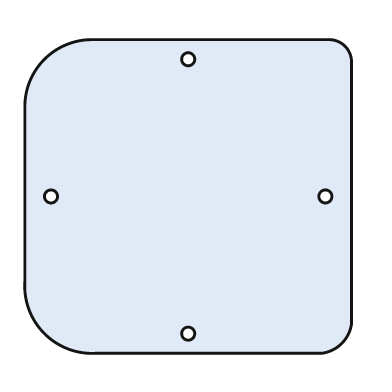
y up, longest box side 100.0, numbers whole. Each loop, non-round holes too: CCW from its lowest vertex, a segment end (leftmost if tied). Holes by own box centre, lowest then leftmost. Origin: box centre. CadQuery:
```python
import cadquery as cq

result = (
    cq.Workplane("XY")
    .moveTo(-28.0, -48.0)
    .lineTo(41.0, -48.0)
    .threePointArc((47.0, -45.0), (50.0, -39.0))
    .lineTo(50.0, 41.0)
    .threePointArc((48.0, 46.0), (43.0, 48.0))
    .lineTo(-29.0, 48.0)
    .threePointArc((-44.0, 42.0), (-50.0, 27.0))
    .lineTo(-50.0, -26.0)
    .threePointArc((-44.0, -42.0), (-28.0, -48.0))
    .close()
    .moveTo(0.0, -42.0)
    .circle(2.0)
    .moveTo(-42.0, 0.0)
    .circle(2.0)
    .moveTo(42.0, 0.0)
    .circle(2.0)
    .moveTo(0.0, 42.0)
    .circle(2.0)
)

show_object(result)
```